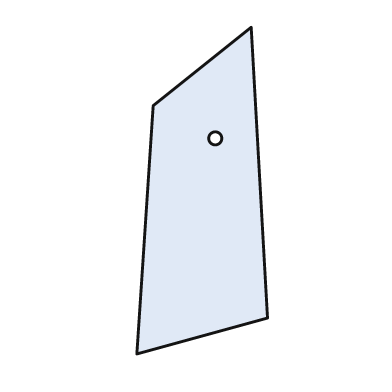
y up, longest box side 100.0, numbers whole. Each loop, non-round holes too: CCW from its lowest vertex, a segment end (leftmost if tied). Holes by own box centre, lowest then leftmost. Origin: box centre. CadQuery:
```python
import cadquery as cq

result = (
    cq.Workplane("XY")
    .moveTo(-20.0, -50.0)
    .lineTo(20.0, -39.0)
    .lineTo(15.0, 50.0)
    .lineTo(-15.0, 26.0)
    .close()
    .moveTo(4.0, 16.0)
    .circle(2.0)
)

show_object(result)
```